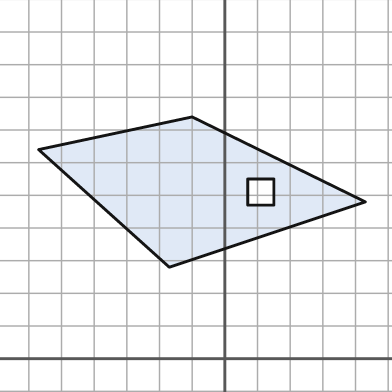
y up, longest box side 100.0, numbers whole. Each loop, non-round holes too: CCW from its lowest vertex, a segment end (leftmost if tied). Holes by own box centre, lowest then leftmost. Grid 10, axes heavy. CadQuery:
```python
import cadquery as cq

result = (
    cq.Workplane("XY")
    .moveTo(-17.0, 28.0)
    .lineTo(43.0, 48.0)
    .lineTo(-10.0, 74.0)
    .lineTo(-57.0, 64.0)
    .close()
    .moveTo(7.0, 47.0)
    .lineTo(15.0, 47.0)
    .lineTo(15.0, 55.0)
    .lineTo(7.0, 55.0)
    .close()
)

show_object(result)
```